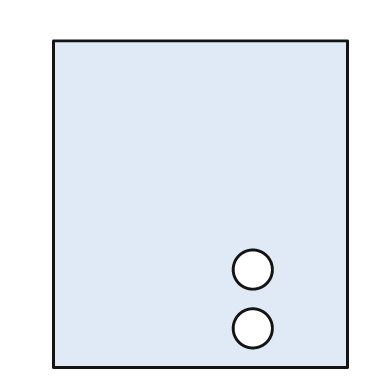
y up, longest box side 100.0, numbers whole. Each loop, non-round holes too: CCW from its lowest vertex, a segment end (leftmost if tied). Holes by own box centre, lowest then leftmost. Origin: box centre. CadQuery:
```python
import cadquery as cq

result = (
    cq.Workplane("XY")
    .moveTo(-45.0, -50.0)
    .lineTo(45.0, -50.0)
    .lineTo(45.0, 50.0)
    .lineTo(-45.0, 50.0)
    .close()
    .moveTo(16.0, -38.0)
    .circle(6.0)
    .moveTo(16.0, -20.0)
    .circle(6.0)
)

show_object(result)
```